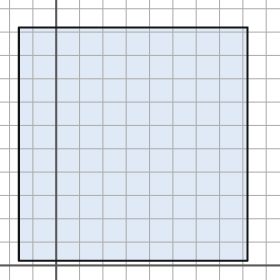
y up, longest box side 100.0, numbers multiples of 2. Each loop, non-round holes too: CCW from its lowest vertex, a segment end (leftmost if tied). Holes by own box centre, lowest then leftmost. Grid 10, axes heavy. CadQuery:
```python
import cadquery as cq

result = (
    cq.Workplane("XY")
    .moveTo(-16.0, 2.0)
    .lineTo(82.0, 2.0)
    .lineTo(82.0, 102.0)
    .lineTo(-16.0, 102.0)
    .close()
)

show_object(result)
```